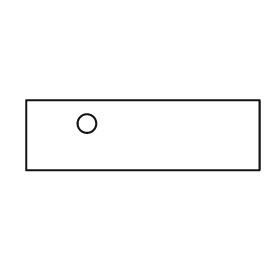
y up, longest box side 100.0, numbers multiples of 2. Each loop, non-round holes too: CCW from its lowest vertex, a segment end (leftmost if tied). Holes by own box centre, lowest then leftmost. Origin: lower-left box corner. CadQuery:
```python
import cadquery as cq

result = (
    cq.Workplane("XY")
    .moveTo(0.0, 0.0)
    .lineTo(100.0, 0.0)
    .lineTo(100.0, 30.0)
    .lineTo(0.0, 30.0)
    .close()
    .moveTo(26.0, 20.0)
    .circle(4.0)
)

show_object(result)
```